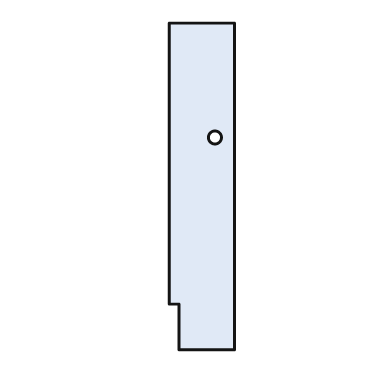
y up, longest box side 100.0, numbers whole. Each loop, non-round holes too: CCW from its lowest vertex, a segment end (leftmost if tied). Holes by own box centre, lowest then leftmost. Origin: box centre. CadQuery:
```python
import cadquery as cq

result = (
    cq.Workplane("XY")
    .moveTo(-7.0, -50.0)
    .lineTo(10.0, -50.0)
    .lineTo(10.0, 50.0)
    .lineTo(-10.0, 50.0)
    .lineTo(-10.0, -36.0)
    .lineTo(-7.0, -36.0)
    .close()
    .moveTo(4.0, 15.0)
    .circle(2.0)
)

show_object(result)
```